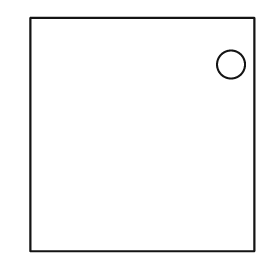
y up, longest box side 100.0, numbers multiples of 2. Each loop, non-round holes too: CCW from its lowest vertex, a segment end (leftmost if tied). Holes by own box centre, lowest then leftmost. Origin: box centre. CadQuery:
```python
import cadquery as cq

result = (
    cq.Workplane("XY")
    .moveTo(-48.0, -50.0)
    .lineTo(48.0, -50.0)
    .lineTo(48.0, 50.0)
    .lineTo(-48.0, 50.0)
    .close()
    .moveTo(38.0, 30.0)
    .circle(6.0)
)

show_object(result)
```